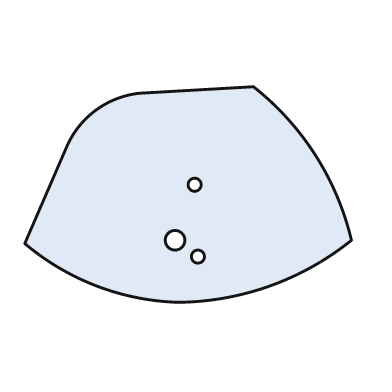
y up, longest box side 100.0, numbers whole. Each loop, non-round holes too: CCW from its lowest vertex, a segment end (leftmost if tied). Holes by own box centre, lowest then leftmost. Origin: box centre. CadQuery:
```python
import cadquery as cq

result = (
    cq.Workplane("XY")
    .moveTo(-3.0, -33.0)
    .threePointArc((25.0, -28.0), (50.0, -14.0))
    .threePointArc((39.0, 12.0), (20.0, 33.0))
    .lineTo(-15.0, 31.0)
    .threePointArc((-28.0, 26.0), (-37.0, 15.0))
    .lineTo(-50.0, -15.0)
    .threePointArc((-28.0, -28.0), (-3.0, -33.0))
    .close()
    .moveTo(3.0, -19.0)
    .circle(2.0)
    .moveTo(-4.0, -14.0)
    .circle(3.0)
    .moveTo(2.0, 3.0)
    .circle(2.0)
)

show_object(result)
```